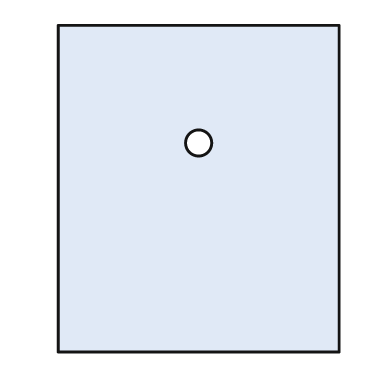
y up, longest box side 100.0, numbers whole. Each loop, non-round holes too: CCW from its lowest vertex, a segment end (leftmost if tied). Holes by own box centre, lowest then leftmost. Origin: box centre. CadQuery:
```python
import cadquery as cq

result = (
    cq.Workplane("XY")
    .moveTo(-43.0, -50.0)
    .lineTo(43.0, -50.0)
    .lineTo(43.0, 50.0)
    .lineTo(-43.0, 50.0)
    .close()
    .moveTo(0.0, 14.0)
    .circle(4.0)
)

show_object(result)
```